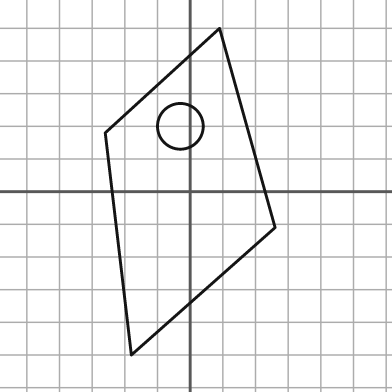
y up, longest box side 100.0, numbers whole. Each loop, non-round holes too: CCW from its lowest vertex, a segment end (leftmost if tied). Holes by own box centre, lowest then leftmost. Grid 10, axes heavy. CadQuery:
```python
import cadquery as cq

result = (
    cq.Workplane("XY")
    .moveTo(-18.0, -50.0)
    .lineTo(26.0, -11.0)
    .lineTo(9.0, 50.0)
    .lineTo(-26.0, 18.0)
    .close()
    .moveTo(-3.0, 20.0)
    .circle(7.0)
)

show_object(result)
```